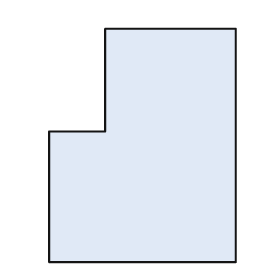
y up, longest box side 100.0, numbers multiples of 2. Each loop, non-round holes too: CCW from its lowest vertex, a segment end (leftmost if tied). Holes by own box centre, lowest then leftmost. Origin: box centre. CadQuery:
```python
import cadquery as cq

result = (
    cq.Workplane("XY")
    .moveTo(-40.0, -50.0)
    .lineTo(40.0, -50.0)
    .lineTo(40.0, 50.0)
    .lineTo(-16.0, 50.0)
    .lineTo(-16.0, 6.0)
    .lineTo(-40.0, 6.0)
    .close()
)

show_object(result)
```